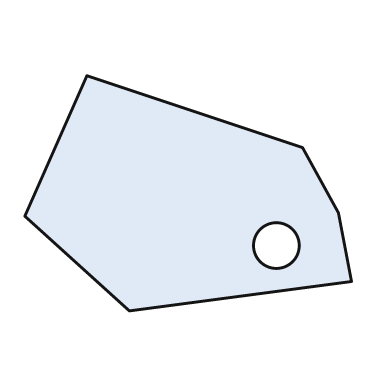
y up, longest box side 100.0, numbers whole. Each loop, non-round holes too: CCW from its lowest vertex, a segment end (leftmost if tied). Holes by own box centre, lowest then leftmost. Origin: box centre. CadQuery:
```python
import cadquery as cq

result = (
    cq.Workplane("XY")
    .moveTo(-18.0, -36.0)
    .lineTo(50.0, -27.0)
    .lineTo(46.0, -6.0)
    .lineTo(35.0, 14.0)
    .lineTo(-31.0, 36.0)
    .lineTo(-50.0, -7.0)
    .close()
    .moveTo(27.0, -16.0)
    .circle(7.0)
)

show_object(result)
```